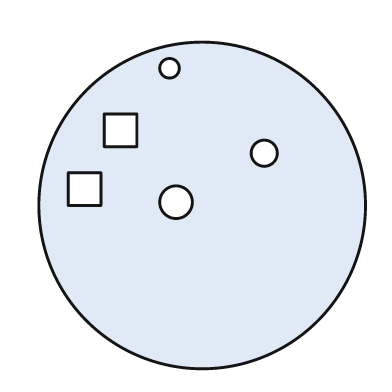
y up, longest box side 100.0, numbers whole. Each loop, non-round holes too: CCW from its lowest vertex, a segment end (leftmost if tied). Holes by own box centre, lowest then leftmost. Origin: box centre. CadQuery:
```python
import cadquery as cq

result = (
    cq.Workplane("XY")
    .moveTo(0.0, 0.0)
    .circle(50.0)
    .moveTo(-8.0, 1.0)
    .circle(5.0)
    .moveTo(-41.0, 0.0)
    .lineTo(-31.0, 0.0)
    .lineTo(-31.0, 10.0)
    .lineTo(-41.0, 10.0)
    .close()
    .moveTo(19.0, 16.0)
    .circle(4.0)
    .moveTo(-30.0, 18.0)
    .lineTo(-20.0, 18.0)
    .lineTo(-20.0, 28.0)
    .lineTo(-30.0, 28.0)
    .close()
    .moveTo(-10.0, 42.0)
    .circle(3.0)
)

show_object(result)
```